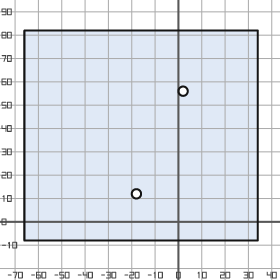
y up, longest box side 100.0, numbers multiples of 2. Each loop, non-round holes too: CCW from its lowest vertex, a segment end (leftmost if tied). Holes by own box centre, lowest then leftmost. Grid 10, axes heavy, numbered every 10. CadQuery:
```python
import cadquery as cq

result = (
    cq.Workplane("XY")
    .moveTo(-66.0, -8.0)
    .lineTo(34.0, -8.0)
    .lineTo(34.0, 82.0)
    .lineTo(-66.0, 82.0)
    .close()
    .moveTo(-18.0, 12.0)
    .circle(2.0)
    .moveTo(2.0, 56.0)
    .circle(2.0)
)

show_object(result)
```